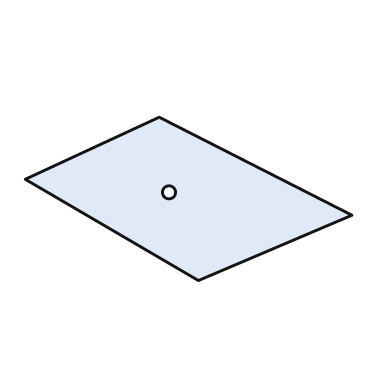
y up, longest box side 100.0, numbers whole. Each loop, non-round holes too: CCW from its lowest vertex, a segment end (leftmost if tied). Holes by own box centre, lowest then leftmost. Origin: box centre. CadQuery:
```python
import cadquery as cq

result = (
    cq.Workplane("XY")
    .moveTo(3.0, -25.0)
    .lineTo(50.0, -5.0)
    .lineTo(-9.0, 25.0)
    .lineTo(-50.0, 6.0)
    .close()
    .moveTo(-6.0, 2.0)
    .circle(2.0)
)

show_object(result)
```